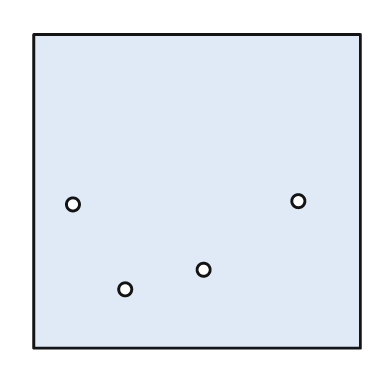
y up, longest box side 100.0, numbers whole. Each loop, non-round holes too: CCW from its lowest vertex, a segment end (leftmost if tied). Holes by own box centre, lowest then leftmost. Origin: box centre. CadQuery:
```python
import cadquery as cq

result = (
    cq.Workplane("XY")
    .moveTo(-50.0, -48.0)
    .lineTo(50.0, -48.0)
    .lineTo(50.0, 48.0)
    .lineTo(-50.0, 48.0)
    .close()
    .moveTo(-22.0, -30.0)
    .circle(2.0)
    .moveTo(2.0, -24.0)
    .circle(2.0)
    .moveTo(-38.0, -4.0)
    .circle(2.0)
    .moveTo(31.0, -3.0)
    .circle(2.0)
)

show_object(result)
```